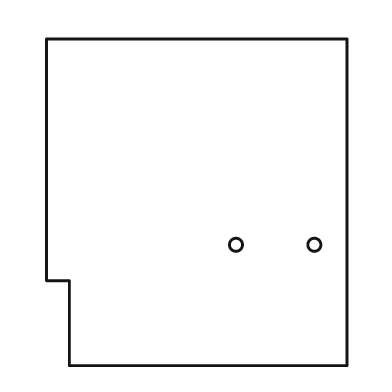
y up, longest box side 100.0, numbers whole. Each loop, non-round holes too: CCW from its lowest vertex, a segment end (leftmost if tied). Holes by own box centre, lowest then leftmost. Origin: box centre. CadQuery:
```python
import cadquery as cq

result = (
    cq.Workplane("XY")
    .moveTo(-39.0, -50.0)
    .lineTo(46.0, -50.0)
    .lineTo(46.0, 50.0)
    .lineTo(-46.0, 50.0)
    .lineTo(-46.0, -24.0)
    .lineTo(-39.0, -24.0)
    .close()
    .moveTo(12.0, -13.0)
    .circle(2.0)
    .moveTo(36.0, -13.0)
    .circle(2.0)
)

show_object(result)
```